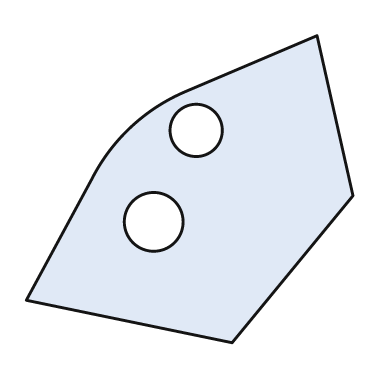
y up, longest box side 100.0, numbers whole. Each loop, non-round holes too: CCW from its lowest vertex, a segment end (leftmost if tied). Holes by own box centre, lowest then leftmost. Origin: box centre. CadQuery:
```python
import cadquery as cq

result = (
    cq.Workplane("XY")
    .moveTo(13.0, -47.0)
    .lineTo(50.0, -2.0)
    .lineTo(39.0, 47.0)
    .lineTo(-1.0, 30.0)
    .threePointArc((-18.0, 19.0), (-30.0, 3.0))
    .lineTo(-50.0, -34.0)
    .close()
    .moveTo(-11.0, -10.0)
    .circle(9.0)
    .moveTo(2.0, 18.0)
    .circle(8.0)
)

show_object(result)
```